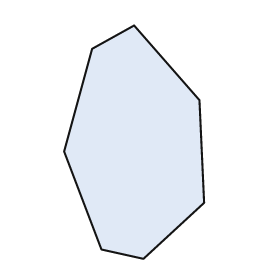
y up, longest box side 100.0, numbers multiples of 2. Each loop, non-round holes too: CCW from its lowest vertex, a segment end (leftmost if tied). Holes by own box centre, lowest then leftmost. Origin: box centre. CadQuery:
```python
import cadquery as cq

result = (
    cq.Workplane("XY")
    .moveTo(4.0, -50.0)
    .lineTo(30.0, -26.0)
    .lineTo(28.0, 18.0)
    .lineTo(0.0, 50.0)
    .lineTo(-18.0, 40.0)
    .lineTo(-30.0, -4.0)
    .lineTo(-14.0, -46.0)
    .close()
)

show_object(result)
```